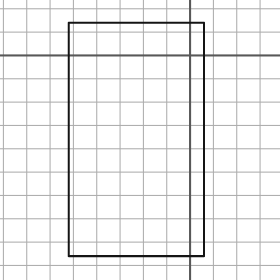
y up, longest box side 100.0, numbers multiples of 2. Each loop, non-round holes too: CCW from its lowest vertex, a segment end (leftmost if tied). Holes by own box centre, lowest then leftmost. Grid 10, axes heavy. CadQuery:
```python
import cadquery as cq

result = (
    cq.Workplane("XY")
    .moveTo(-52.0, -86.0)
    .lineTo(6.0, -86.0)
    .lineTo(6.0, 14.0)
    .lineTo(-52.0, 14.0)
    .close()
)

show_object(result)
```